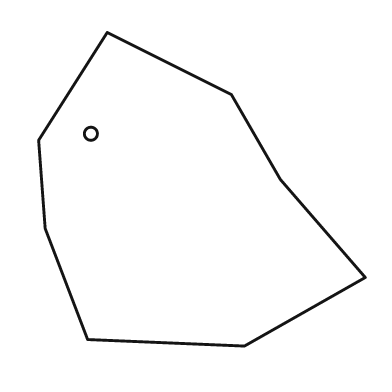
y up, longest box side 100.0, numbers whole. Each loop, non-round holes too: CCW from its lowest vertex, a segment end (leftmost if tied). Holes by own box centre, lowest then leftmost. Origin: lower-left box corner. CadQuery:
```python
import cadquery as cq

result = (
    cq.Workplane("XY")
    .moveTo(63.0, 0.0)
    .lineTo(100.0, 21.0)
    .lineTo(74.0, 51.0)
    .lineTo(59.0, 77.0)
    .lineTo(21.0, 96.0)
    .lineTo(0.0, 63.0)
    .lineTo(2.0, 36.0)
    .lineTo(15.0, 2.0)
    .close()
    .moveTo(16.0, 65.0)
    .circle(2.0)
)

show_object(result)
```